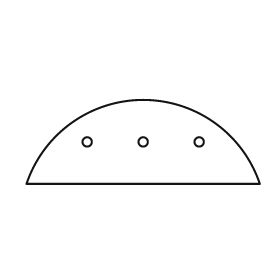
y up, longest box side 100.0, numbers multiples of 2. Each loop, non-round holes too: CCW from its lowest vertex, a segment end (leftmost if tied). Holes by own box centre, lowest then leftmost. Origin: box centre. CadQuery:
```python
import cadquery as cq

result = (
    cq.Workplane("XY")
    .moveTo(-50.0, -18.0)
    .lineTo(50.0, -18.0)
    .threePointArc((0.0, 18.0), (-50.0, -18.0))
    .close()
    .moveTo(-24.0, 0.0)
    .circle(2.0)
    .moveTo(0.0, 0.0)
    .circle(2.0)
    .moveTo(24.0, 0.0)
    .circle(2.0)
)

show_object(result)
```